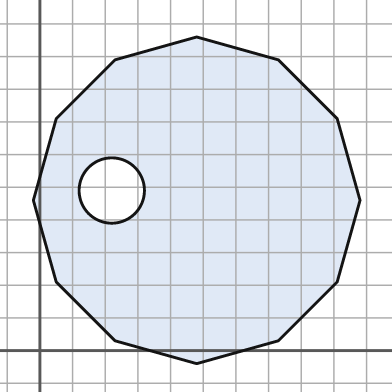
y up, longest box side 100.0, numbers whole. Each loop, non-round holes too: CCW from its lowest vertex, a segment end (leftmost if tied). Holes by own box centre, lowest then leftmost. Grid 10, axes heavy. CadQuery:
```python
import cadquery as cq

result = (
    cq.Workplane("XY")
    .moveTo(48.0, -4.0)
    .lineTo(73.0, 3.0)
    .lineTo(91.0, 21.0)
    .lineTo(98.0, 46.0)
    .lineTo(91.0, 71.0)
    .lineTo(73.0, 89.0)
    .lineTo(48.0, 96.0)
    .lineTo(23.0, 89.0)
    .lineTo(5.0, 71.0)
    .lineTo(-2.0, 46.0)
    .lineTo(5.0, 21.0)
    .lineTo(23.0, 3.0)
    .close()
    .moveTo(22.0, 49.0)
    .circle(10.0)
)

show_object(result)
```